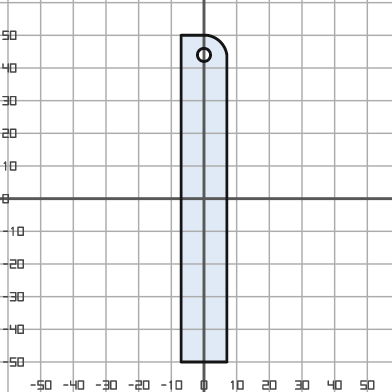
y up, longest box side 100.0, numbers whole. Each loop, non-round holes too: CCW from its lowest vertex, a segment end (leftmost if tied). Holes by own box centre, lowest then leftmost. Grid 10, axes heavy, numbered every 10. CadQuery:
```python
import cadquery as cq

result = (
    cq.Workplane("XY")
    .moveTo(-7.0, -50.0)
    .lineTo(7.0, -50.0)
    .lineTo(7.0, 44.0)
    .threePointArc((5.0, 48.0), (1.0, 50.0))
    .lineTo(-7.0, 50.0)
    .close()
    .moveTo(0.0, 44.0)
    .circle(2.0)
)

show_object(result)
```